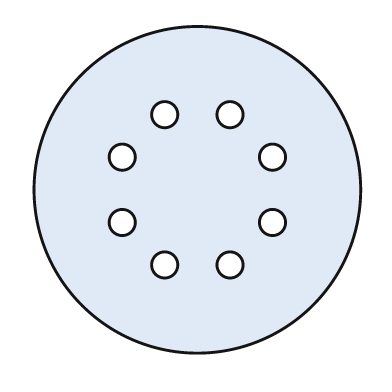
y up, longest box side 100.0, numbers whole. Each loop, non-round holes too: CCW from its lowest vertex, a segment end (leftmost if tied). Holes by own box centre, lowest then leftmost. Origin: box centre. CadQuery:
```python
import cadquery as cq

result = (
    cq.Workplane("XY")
    .moveTo(0.0, 0.0)
    .circle(50.0)
    .moveTo(-10.0, -23.0)
    .circle(4.0)
    .moveTo(10.0, -23.0)
    .circle(4.0)
    .moveTo(-23.0, -10.0)
    .circle(4.0)
    .moveTo(23.0, -10.0)
    .circle(4.0)
    .moveTo(-23.0, 10.0)
    .circle(4.0)
    .moveTo(23.0, 10.0)
    .circle(4.0)
    .moveTo(-10.0, 23.0)
    .circle(4.0)
    .moveTo(10.0, 23.0)
    .circle(4.0)
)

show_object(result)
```